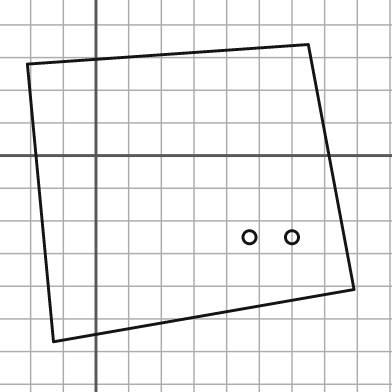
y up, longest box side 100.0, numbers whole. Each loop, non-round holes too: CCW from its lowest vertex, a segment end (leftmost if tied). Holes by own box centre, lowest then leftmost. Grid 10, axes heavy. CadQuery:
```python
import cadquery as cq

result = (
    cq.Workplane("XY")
    .moveTo(-13.0, -57.0)
    .lineTo(79.0, -41.0)
    .lineTo(65.0, 34.0)
    .lineTo(-21.0, 28.0)
    .close()
    .moveTo(47.0, -25.0)
    .circle(2.0)
    .moveTo(60.0, -25.0)
    .circle(2.0)
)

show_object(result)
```